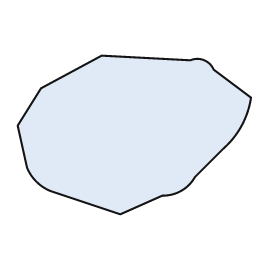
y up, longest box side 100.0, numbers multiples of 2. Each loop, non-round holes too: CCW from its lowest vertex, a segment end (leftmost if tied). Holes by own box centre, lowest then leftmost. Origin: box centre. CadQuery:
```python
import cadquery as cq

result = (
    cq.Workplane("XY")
    .moveTo(-6.0, -34.0)
    .lineTo(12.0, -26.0)
    .threePointArc((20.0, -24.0), (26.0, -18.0))
    .lineTo(38.0, -6.0)
    .threePointArc((46.0, 4.0), (50.0, 16.0))
    .lineTo(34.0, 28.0)
    .threePointArc((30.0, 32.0), (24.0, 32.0))
    .lineTo(-14.0, 34.0)
    .lineTo(-40.0, 20.0)
    .lineTo(-50.0, 4.0)
    .lineTo(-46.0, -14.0)
    .threePointArc((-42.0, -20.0), (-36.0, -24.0))
    .close()
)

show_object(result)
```